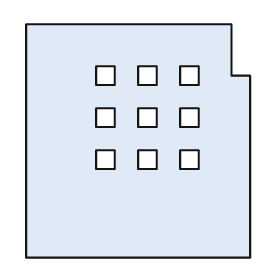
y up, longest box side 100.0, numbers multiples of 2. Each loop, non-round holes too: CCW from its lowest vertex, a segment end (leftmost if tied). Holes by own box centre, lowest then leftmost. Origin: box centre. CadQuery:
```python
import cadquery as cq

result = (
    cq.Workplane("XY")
    .moveTo(-48.0, -50.0)
    .lineTo(48.0, -50.0)
    .lineTo(48.0, 28.0)
    .lineTo(40.0, 28.0)
    .lineTo(40.0, 50.0)
    .lineTo(-48.0, 50.0)
    .close()
    .moveTo(-18.0, -12.0)
    .lineTo(-10.0, -12.0)
    .lineTo(-10.0, -4.0)
    .lineTo(-18.0, -4.0)
    .close()
    .moveTo(0.0, -12.0)
    .lineTo(8.0, -12.0)
    .lineTo(8.0, -4.0)
    .lineTo(0.0, -4.0)
    .close()
    .moveTo(18.0, -12.0)
    .lineTo(26.0, -12.0)
    .lineTo(26.0, -4.0)
    .lineTo(18.0, -4.0)
    .close()
    .moveTo(-18.0, 6.0)
    .lineTo(-10.0, 6.0)
    .lineTo(-10.0, 14.0)
    .lineTo(-18.0, 14.0)
    .close()
    .moveTo(0.0, 6.0)
    .lineTo(8.0, 6.0)
    .lineTo(8.0, 14.0)
    .lineTo(0.0, 14.0)
    .close()
    .moveTo(18.0, 6.0)
    .lineTo(26.0, 6.0)
    .lineTo(26.0, 14.0)
    .lineTo(18.0, 14.0)
    .close()
    .moveTo(-18.0, 24.0)
    .lineTo(-10.0, 24.0)
    .lineTo(-10.0, 32.0)
    .lineTo(-18.0, 32.0)
    .close()
    .moveTo(0.0, 24.0)
    .lineTo(8.0, 24.0)
    .lineTo(8.0, 32.0)
    .lineTo(0.0, 32.0)
    .close()
    .moveTo(18.0, 24.0)
    .lineTo(26.0, 24.0)
    .lineTo(26.0, 32.0)
    .lineTo(18.0, 32.0)
    .close()
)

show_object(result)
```